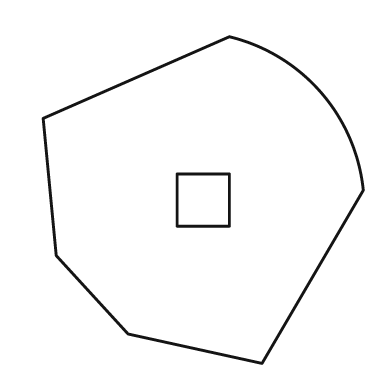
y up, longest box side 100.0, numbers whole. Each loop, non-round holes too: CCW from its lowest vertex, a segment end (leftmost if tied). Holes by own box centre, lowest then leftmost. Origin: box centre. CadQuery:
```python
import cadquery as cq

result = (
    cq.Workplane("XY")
    .moveTo(18.0, -50.0)
    .lineTo(49.0, 3.0)
    .threePointArc((36.0, 33.0), (8.0, 50.0))
    .lineTo(-49.0, 25.0)
    .lineTo(-45.0, -17.0)
    .lineTo(-23.0, -41.0)
    .close()
    .moveTo(-8.0, -8.0)
    .lineTo(8.0, -8.0)
    .lineTo(8.0, 8.0)
    .lineTo(-8.0, 8.0)
    .close()
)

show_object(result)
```